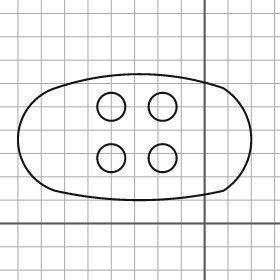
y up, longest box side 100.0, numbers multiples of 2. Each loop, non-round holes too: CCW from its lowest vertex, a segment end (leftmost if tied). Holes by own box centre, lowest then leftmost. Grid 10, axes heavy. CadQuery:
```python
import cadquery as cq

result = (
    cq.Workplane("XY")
    .moveTo(-64.0, 14.0)
    .threePointArc((-28.0, 10.0), (8.0, 14.0))
    .threePointArc((20.0, 36.0), (8.0, 58.0))
    .threePointArc((-28.0, 64.0), (-64.0, 58.0))
    .threePointArc((-80.0, 36.0), (-64.0, 14.0))
    .close()
    .moveTo(-40.0, 28.0)
    .circle(6.0)
    .moveTo(-18.0, 28.0)
    .circle(6.0)
    .moveTo(-40.0, 50.0)
    .circle(6.0)
    .moveTo(-18.0, 50.0)
    .circle(6.0)
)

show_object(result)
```